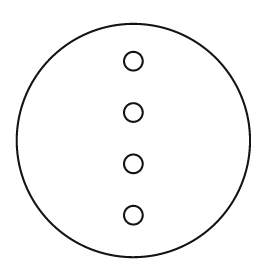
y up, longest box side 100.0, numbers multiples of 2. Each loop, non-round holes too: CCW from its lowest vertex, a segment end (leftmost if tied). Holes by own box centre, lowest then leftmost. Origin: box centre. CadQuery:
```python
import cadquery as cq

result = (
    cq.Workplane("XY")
    .moveTo(0.0, 0.0)
    .circle(50.0)
    .moveTo(0.0, -32.0)
    .circle(4.0)
    .moveTo(0.0, -10.0)
    .circle(4.0)
    .moveTo(0.0, 12.0)
    .circle(4.0)
    .moveTo(0.0, 34.0)
    .circle(4.0)
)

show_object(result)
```